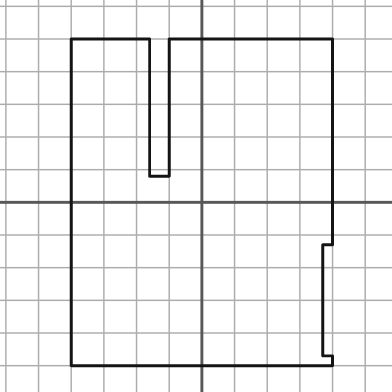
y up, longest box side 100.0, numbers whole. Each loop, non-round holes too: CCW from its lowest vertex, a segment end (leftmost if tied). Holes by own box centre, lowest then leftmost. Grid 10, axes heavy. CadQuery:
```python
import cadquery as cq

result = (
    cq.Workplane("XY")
    .moveTo(-40.0, -50.0)
    .lineTo(40.0, -50.0)
    .lineTo(40.0, -47.0)
    .lineTo(37.0, -47.0)
    .lineTo(37.0, -13.0)
    .lineTo(40.0, -13.0)
    .lineTo(40.0, 50.0)
    .lineTo(-10.0, 50.0)
    .lineTo(-10.0, 8.0)
    .lineTo(-16.0, 8.0)
    .lineTo(-16.0, 50.0)
    .lineTo(-40.0, 50.0)
    .close()
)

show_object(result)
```